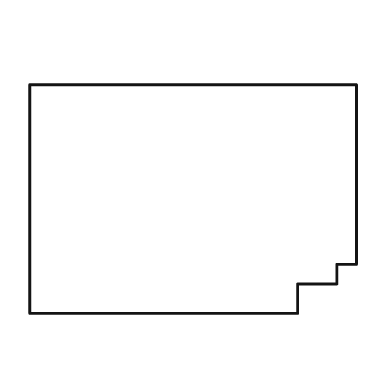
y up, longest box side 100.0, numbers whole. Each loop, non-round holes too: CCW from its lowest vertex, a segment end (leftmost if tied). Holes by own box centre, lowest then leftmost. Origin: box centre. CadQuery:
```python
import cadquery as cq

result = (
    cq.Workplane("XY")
    .moveTo(-50.0, -35.0)
    .lineTo(32.0, -35.0)
    .lineTo(32.0, -26.0)
    .lineTo(44.0, -26.0)
    .lineTo(44.0, -20.0)
    .lineTo(50.0, -20.0)
    .lineTo(50.0, 35.0)
    .lineTo(-50.0, 35.0)
    .close()
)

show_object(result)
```